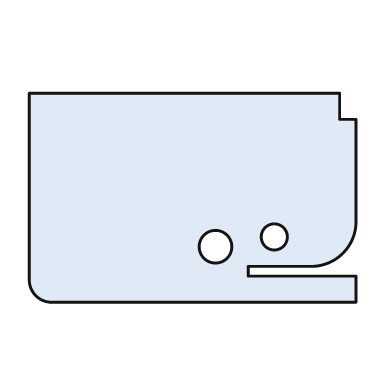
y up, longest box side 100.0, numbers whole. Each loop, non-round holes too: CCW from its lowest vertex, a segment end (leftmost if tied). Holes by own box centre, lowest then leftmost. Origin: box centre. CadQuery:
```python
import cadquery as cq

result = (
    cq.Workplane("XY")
    .moveTo(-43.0, -32.0)
    .lineTo(50.0, -32.0)
    .lineTo(50.0, -24.0)
    .lineTo(17.0, -24.0)
    .lineTo(17.0, -21.0)
    .lineTo(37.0, -21.0)
    .threePointArc((46.0, -17.0), (50.0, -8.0))
    .lineTo(50.0, 24.0)
    .lineTo(45.0, 24.0)
    .lineTo(45.0, 32.0)
    .lineTo(-50.0, 32.0)
    .lineTo(-50.0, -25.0)
    .threePointArc((-48.0, -30.0), (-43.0, -32.0))
    .close()
    .moveTo(7.0, -15.0)
    .circle(5.0)
    .moveTo(25.0, -12.0)
    .circle(4.0)
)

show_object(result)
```